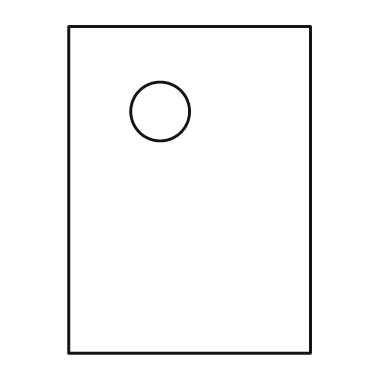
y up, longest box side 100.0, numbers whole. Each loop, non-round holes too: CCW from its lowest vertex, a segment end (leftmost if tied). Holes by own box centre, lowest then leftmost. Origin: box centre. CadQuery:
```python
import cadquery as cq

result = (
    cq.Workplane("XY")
    .moveTo(-37.0, -50.0)
    .lineTo(37.0, -50.0)
    .lineTo(37.0, 50.0)
    .lineTo(-37.0, 50.0)
    .close()
    .moveTo(-9.0, 24.0)
    .circle(9.0)
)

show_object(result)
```